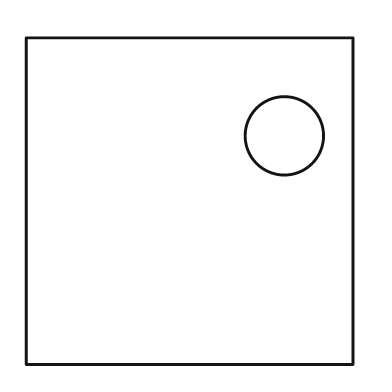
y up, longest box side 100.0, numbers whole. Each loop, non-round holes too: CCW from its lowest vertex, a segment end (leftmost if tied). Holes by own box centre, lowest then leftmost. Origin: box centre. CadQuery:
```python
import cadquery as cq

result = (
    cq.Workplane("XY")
    .moveTo(-50.0, -50.0)
    .lineTo(50.0, -50.0)
    .lineTo(50.0, 50.0)
    .lineTo(-50.0, 50.0)
    .close()
    .moveTo(29.0, 20.0)
    .circle(12.0)
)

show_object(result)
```